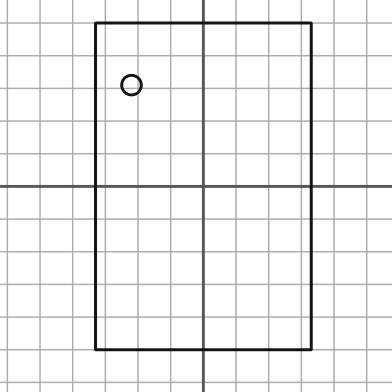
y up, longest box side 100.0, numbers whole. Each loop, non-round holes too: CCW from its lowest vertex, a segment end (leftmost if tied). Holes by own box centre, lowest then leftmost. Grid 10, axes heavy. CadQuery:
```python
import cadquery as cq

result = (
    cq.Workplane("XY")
    .moveTo(-33.0, -50.0)
    .lineTo(33.0, -50.0)
    .lineTo(33.0, 50.0)
    .lineTo(-33.0, 50.0)
    .close()
    .moveTo(-22.0, 31.0)
    .circle(3.0)
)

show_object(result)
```